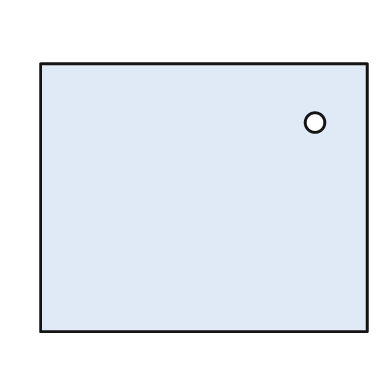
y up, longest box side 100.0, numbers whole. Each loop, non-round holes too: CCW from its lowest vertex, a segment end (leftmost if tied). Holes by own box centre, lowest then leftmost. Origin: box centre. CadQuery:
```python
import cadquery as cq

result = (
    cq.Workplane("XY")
    .moveTo(-50.0, -41.0)
    .lineTo(50.0, -41.0)
    .lineTo(50.0, 41.0)
    .lineTo(-50.0, 41.0)
    .close()
    .moveTo(34.0, 23.0)
    .circle(3.0)
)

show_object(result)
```